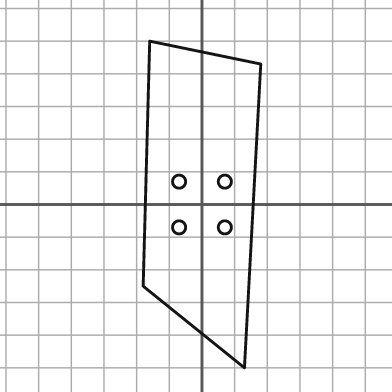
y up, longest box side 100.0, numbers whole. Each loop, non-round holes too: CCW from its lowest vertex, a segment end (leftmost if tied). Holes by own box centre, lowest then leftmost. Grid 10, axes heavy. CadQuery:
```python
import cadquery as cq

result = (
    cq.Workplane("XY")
    .moveTo(13.0, -50.0)
    .lineTo(18.0, 43.0)
    .lineTo(-16.0, 50.0)
    .lineTo(-18.0, -25.0)
    .close()
    .moveTo(-7.0, -7.0)
    .circle(2.0)
    .moveTo(7.0, -7.0)
    .circle(2.0)
    .moveTo(-7.0, 7.0)
    .circle(2.0)
    .moveTo(7.0, 7.0)
    .circle(2.0)
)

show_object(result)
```